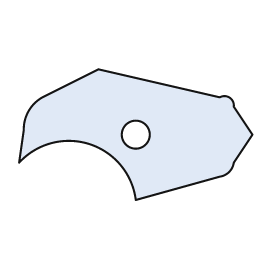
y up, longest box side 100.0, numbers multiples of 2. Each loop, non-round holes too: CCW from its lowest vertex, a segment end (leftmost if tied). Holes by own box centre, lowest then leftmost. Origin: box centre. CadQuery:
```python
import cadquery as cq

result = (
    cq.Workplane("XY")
    .moveTo(0.0, -28.0)
    .lineTo(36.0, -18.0)
    .threePointArc((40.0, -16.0), (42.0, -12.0))
    .lineTo(50.0, 0.0)
    .lineTo(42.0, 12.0)
    .threePointArc((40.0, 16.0), (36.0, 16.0))
    .lineTo(-16.0, 28.0)
    .lineTo(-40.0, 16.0)
    .threePointArc((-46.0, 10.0), (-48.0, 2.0))
    .lineTo(-50.0, -12.0)
    .threePointArc((-20.0, -4.0), (0.0, -28.0))
    .close()
    .moveTo(0.0, 0.0)
    .circle(6.0)
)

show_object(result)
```